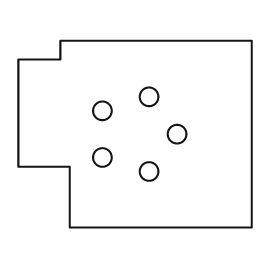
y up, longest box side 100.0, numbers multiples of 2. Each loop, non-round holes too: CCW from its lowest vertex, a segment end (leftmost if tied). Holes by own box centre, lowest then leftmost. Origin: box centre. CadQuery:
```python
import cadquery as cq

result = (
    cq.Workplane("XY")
    .moveTo(-28.0, -40.0)
    .lineTo(50.0, -40.0)
    .lineTo(50.0, 40.0)
    .lineTo(-32.0, 40.0)
    .lineTo(-32.0, 32.0)
    .lineTo(-50.0, 32.0)
    .lineTo(-50.0, -14.0)
    .lineTo(-28.0, -14.0)
    .close()
    .moveTo(6.0, -16.0)
    .circle(4.0)
    .moveTo(-14.0, -10.0)
    .circle(4.0)
    .moveTo(18.0, 0.0)
    .circle(4.0)
    .moveTo(-14.0, 10.0)
    .circle(4.0)
    .moveTo(6.0, 16.0)
    .circle(4.0)
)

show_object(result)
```